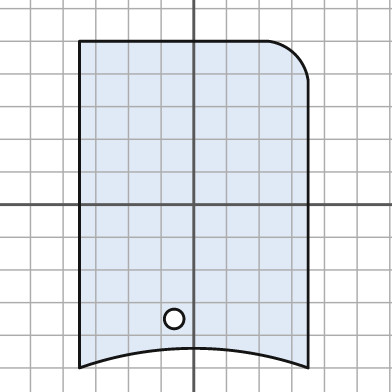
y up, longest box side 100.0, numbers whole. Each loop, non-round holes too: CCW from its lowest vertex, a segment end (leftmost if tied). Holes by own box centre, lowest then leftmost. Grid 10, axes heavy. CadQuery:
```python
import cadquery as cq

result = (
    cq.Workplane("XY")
    .moveTo(-35.0, -50.0)
    .threePointArc((0.0, -44.0), (35.0, -50.0))
    .lineTo(35.0, 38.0)
    .threePointArc((31.0, 46.0), (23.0, 50.0))
    .lineTo(-35.0, 50.0)
    .close()
    .moveTo(-6.0, -35.0)
    .circle(3.0)
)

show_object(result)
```